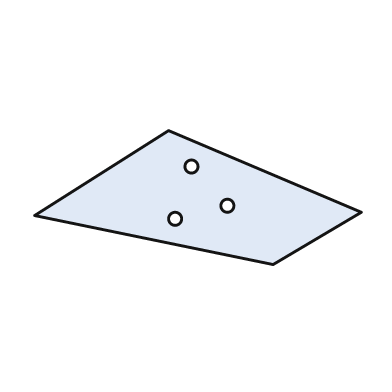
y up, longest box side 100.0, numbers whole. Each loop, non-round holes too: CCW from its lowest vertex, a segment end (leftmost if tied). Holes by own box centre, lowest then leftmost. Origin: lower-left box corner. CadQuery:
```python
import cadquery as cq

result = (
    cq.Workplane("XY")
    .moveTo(73.0, 0.0)
    .lineTo(100.0, 16.0)
    .lineTo(41.0, 41.0)
    .lineTo(0.0, 15.0)
    .close()
    .moveTo(43.0, 14.0)
    .circle(2.0)
    .moveTo(59.0, 18.0)
    .circle(2.0)
    .moveTo(48.0, 30.0)
    .circle(2.0)
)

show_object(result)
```